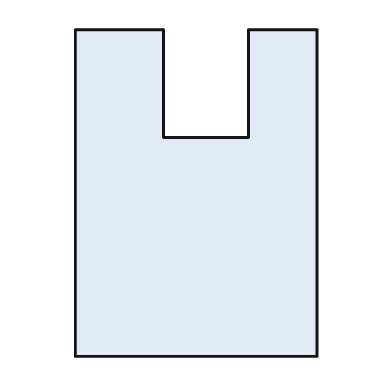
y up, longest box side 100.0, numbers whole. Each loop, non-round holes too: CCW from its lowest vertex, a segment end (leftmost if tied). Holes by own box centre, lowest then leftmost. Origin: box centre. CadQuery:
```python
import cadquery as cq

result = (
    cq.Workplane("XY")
    .moveTo(-37.0, -50.0)
    .lineTo(37.0, -50.0)
    .lineTo(37.0, 50.0)
    .lineTo(16.0, 50.0)
    .lineTo(16.0, 17.0)
    .lineTo(-10.0, 17.0)
    .lineTo(-10.0, 50.0)
    .lineTo(-37.0, 50.0)
    .close()
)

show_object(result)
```